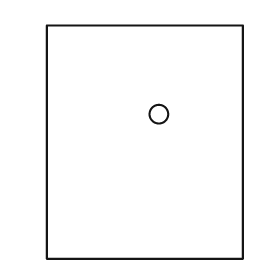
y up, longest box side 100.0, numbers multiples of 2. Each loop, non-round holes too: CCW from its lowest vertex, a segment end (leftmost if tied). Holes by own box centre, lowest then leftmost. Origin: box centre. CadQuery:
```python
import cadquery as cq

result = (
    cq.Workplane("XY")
    .moveTo(-42.0, -50.0)
    .lineTo(42.0, -50.0)
    .lineTo(42.0, 50.0)
    .lineTo(-42.0, 50.0)
    .close()
    .moveTo(6.0, 12.0)
    .circle(4.0)
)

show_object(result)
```